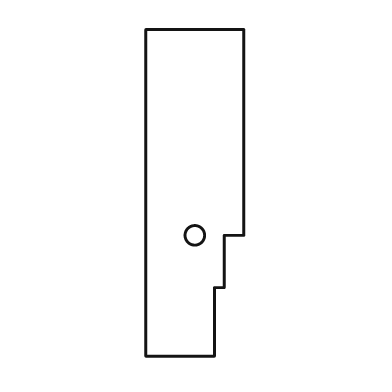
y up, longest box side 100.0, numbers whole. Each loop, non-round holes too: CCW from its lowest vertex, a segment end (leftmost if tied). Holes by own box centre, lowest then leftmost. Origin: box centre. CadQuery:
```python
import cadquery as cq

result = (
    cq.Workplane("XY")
    .moveTo(-15.0, -50.0)
    .lineTo(6.0, -50.0)
    .lineTo(6.0, -29.0)
    .lineTo(9.0, -29.0)
    .lineTo(9.0, -13.0)
    .lineTo(15.0, -13.0)
    .lineTo(15.0, 50.0)
    .lineTo(-15.0, 50.0)
    .close()
    .moveTo(0.0, -13.0)
    .circle(3.0)
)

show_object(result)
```